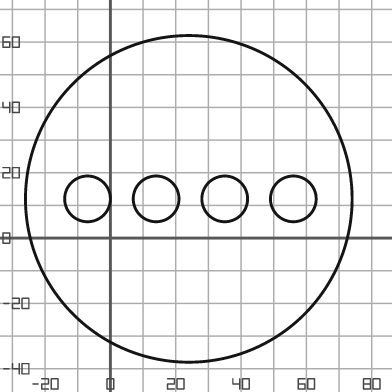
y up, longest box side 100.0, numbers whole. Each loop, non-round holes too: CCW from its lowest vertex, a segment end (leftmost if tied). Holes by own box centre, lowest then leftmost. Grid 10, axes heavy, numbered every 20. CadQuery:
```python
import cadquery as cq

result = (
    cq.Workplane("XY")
    .moveTo(24.0, 12.0)
    .circle(50.0)
    .moveTo(-7.0, 12.0)
    .circle(7.0)
    .moveTo(14.0, 12.0)
    .circle(7.0)
    .moveTo(35.0, 12.0)
    .circle(7.0)
    .moveTo(56.0, 12.0)
    .circle(7.0)
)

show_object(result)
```